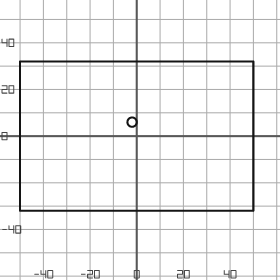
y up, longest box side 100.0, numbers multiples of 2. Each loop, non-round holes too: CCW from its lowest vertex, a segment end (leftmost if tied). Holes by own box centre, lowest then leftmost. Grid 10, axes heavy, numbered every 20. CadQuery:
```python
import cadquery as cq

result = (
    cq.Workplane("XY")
    .moveTo(-50.0, -32.0)
    .lineTo(50.0, -32.0)
    .lineTo(50.0, 32.0)
    .lineTo(-50.0, 32.0)
    .close()
    .moveTo(-2.0, 6.0)
    .circle(2.0)
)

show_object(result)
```